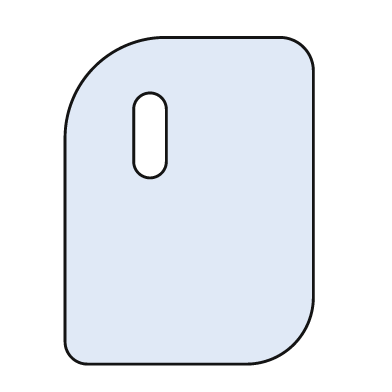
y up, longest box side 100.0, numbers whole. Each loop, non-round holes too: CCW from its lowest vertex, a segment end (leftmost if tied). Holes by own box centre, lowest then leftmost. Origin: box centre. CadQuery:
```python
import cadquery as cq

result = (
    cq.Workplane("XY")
    .moveTo(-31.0, -50.0)
    .lineTo(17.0, -50.0)
    .threePointArc((32.0, -44.0), (38.0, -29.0))
    .lineTo(38.0, 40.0)
    .threePointArc((35.0, 47.0), (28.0, 50.0))
    .lineTo(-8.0, 50.0)
    .threePointArc((-29.0, 41.0), (-38.0, 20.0))
    .lineTo(-38.0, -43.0)
    .threePointArc((-36.0, -48.0), (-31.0, -50.0))
    .close()
    .moveTo(-17.0, 12.0)
    .threePointArc((-12.0, 7.0), (-7.0, 12.0))
    .lineTo(-7.0, 28.0)
    .threePointArc((-12.0, 33.0), (-17.0, 28.0))
    .close()
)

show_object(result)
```